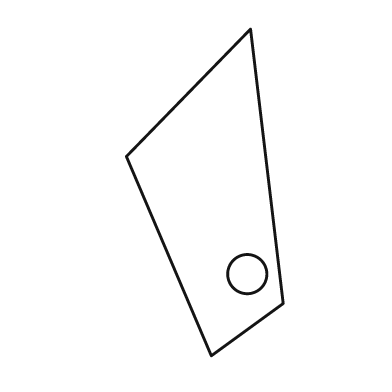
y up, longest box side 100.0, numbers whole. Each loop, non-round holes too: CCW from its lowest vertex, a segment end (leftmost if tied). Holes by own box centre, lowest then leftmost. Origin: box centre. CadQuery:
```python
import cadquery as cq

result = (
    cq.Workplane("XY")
    .moveTo(2.0, -50.0)
    .lineTo(24.0, -34.0)
    .lineTo(14.0, 50.0)
    .lineTo(-24.0, 11.0)
    .close()
    .moveTo(13.0, -25.0)
    .circle(6.0)
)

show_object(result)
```